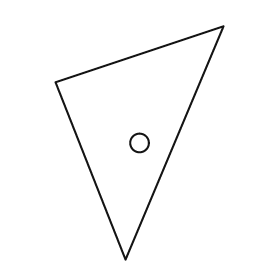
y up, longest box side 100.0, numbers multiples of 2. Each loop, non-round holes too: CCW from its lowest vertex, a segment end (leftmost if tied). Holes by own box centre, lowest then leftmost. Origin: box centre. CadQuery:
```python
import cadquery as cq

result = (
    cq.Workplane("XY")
    .moveTo(-6.0, -50.0)
    .lineTo(36.0, 50.0)
    .lineTo(-36.0, 26.0)
    .close()
    .moveTo(0.0, 0.0)
    .circle(4.0)
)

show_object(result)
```